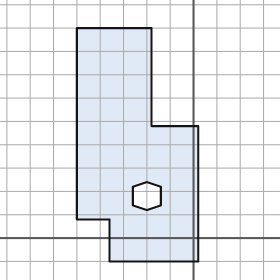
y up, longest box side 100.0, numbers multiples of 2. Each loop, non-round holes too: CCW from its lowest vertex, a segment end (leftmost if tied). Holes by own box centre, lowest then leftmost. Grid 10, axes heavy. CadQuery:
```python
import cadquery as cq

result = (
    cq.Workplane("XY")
    .moveTo(-36.0, -10.0)
    .lineTo(2.0, -10.0)
    .lineTo(2.0, 48.0)
    .lineTo(-18.0, 48.0)
    .lineTo(-18.0, 90.0)
    .lineTo(-50.0, 90.0)
    .lineTo(-50.0, 8.0)
    .lineTo(-36.0, 8.0)
    .close()
    .moveTo(-20.0, 12.0)
    .lineTo(-14.0, 14.0)
    .lineTo(-14.0, 22.0)
    .lineTo(-20.0, 24.0)
    .lineTo(-26.0, 22.0)
    .lineTo(-26.0, 14.0)
    .close()
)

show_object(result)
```